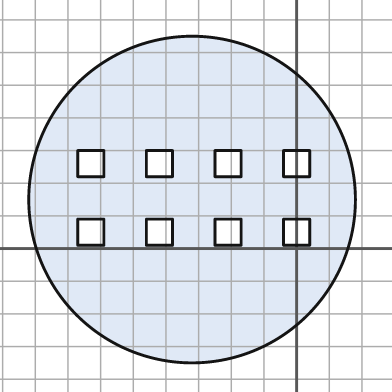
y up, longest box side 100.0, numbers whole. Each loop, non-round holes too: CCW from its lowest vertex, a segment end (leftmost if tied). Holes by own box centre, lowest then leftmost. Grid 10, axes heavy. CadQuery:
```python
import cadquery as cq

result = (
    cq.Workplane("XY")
    .moveTo(-32.0, 15.0)
    .circle(50.0)
    .moveTo(-67.0, 1.0)
    .lineTo(-59.0, 1.0)
    .lineTo(-59.0, 9.0)
    .lineTo(-67.0, 9.0)
    .close()
    .moveTo(-46.0, 1.0)
    .lineTo(-38.0, 1.0)
    .lineTo(-38.0, 9.0)
    .lineTo(-46.0, 9.0)
    .close()
    .moveTo(-25.0, 1.0)
    .lineTo(-17.0, 1.0)
    .lineTo(-17.0, 9.0)
    .lineTo(-25.0, 9.0)
    .close()
    .moveTo(-4.0, 1.0)
    .lineTo(4.0, 1.0)
    .lineTo(4.0, 9.0)
    .lineTo(-4.0, 9.0)
    .close()
    .moveTo(-67.0, 22.0)
    .lineTo(-59.0, 22.0)
    .lineTo(-59.0, 30.0)
    .lineTo(-67.0, 30.0)
    .close()
    .moveTo(-46.0, 22.0)
    .lineTo(-38.0, 22.0)
    .lineTo(-38.0, 30.0)
    .lineTo(-46.0, 30.0)
    .close()
    .moveTo(-25.0, 22.0)
    .lineTo(-17.0, 22.0)
    .lineTo(-17.0, 30.0)
    .lineTo(-25.0, 30.0)
    .close()
    .moveTo(-4.0, 22.0)
    .lineTo(4.0, 22.0)
    .lineTo(4.0, 30.0)
    .lineTo(-4.0, 30.0)
    .close()
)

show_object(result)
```